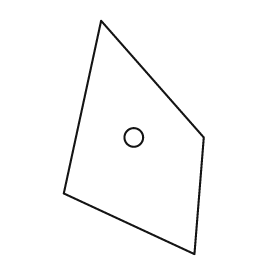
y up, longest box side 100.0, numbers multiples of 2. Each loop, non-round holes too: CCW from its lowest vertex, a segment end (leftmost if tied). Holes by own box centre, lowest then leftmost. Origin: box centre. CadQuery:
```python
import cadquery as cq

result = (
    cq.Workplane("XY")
    .moveTo(26.0, -50.0)
    .lineTo(30.0, 0.0)
    .lineTo(-14.0, 50.0)
    .lineTo(-30.0, -24.0)
    .close()
    .moveTo(0.0, 0.0)
    .circle(4.0)
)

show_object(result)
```